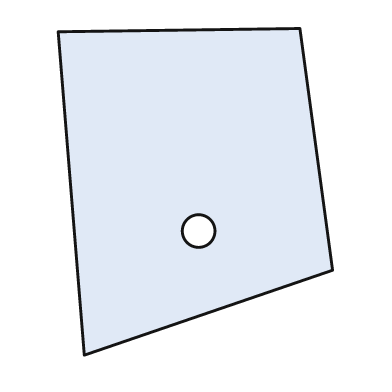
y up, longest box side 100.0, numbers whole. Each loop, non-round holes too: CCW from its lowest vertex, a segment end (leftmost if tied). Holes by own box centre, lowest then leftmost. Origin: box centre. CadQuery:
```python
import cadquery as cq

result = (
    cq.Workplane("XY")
    .moveTo(-34.0, -50.0)
    .lineTo(42.0, -24.0)
    .lineTo(32.0, 50.0)
    .lineTo(-42.0, 49.0)
    .close()
    .moveTo(1.0, -12.0)
    .circle(5.0)
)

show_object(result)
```